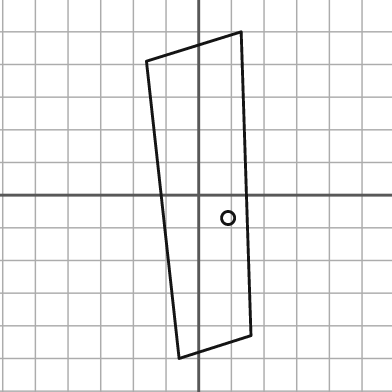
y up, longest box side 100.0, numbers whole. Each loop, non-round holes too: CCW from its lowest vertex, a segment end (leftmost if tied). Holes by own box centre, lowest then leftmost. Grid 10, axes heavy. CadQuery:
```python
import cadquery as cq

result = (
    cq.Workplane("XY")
    .moveTo(-6.0, -50.0)
    .lineTo(16.0, -43.0)
    .lineTo(13.0, 50.0)
    .lineTo(-16.0, 41.0)
    .close()
    .moveTo(9.0, -7.0)
    .circle(2.0)
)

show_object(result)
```